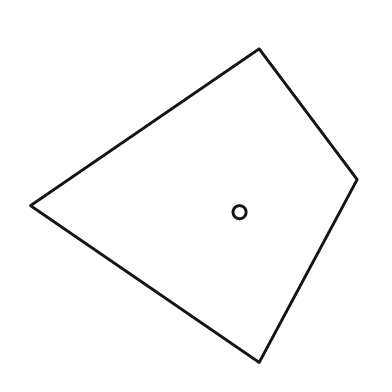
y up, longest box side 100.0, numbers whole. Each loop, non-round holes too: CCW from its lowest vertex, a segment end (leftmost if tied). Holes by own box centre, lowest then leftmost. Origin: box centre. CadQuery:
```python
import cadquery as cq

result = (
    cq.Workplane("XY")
    .moveTo(20.0, -48.0)
    .lineTo(50.0, 8.0)
    .lineTo(20.0, 48.0)
    .lineTo(-50.0, 0.0)
    .close()
    .moveTo(14.0, -2.0)
    .circle(2.0)
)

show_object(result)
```